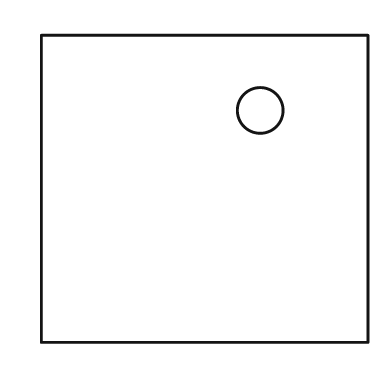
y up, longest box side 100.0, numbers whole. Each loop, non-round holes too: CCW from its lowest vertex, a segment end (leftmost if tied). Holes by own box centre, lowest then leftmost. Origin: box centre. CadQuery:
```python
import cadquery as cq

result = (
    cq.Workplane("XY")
    .moveTo(-50.0, -47.0)
    .lineTo(50.0, -47.0)
    .lineTo(50.0, 47.0)
    .lineTo(-50.0, 47.0)
    .close()
    .moveTo(17.0, 24.0)
    .circle(7.0)
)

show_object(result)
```